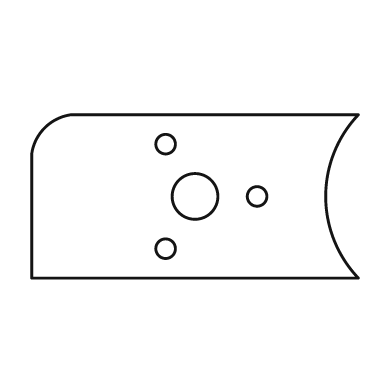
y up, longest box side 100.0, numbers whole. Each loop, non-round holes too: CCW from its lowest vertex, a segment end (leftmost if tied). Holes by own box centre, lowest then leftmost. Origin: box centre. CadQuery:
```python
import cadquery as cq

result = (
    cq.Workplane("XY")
    .moveTo(-50.0, -25.0)
    .lineTo(50.0, -25.0)
    .threePointArc((40.0, 0.0), (50.0, 25.0))
    .lineTo(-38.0, 25.0)
    .threePointArc((-46.0, 21.0), (-50.0, 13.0))
    .close()
    .moveTo(-9.0, -16.0)
    .circle(3.0)
    .moveTo(0.0, 0.0)
    .circle(7.0)
    .moveTo(19.0, 0.0)
    .circle(3.0)
    .moveTo(-9.0, 16.0)
    .circle(3.0)
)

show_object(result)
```